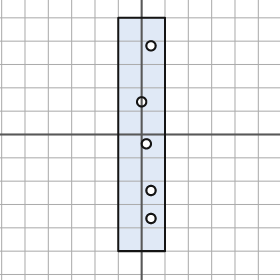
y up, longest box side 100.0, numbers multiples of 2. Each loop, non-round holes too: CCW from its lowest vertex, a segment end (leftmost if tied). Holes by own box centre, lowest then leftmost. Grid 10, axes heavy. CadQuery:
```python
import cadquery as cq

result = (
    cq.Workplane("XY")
    .moveTo(-10.0, -50.0)
    .lineTo(10.0, -50.0)
    .lineTo(10.0, 50.0)
    .lineTo(-10.0, 50.0)
    .close()
    .moveTo(4.0, -36.0)
    .circle(2.0)
    .moveTo(4.0, -24.0)
    .circle(2.0)
    .moveTo(2.0, -4.0)
    .circle(2.0)
    .moveTo(0.0, 14.0)
    .circle(2.0)
    .moveTo(4.0, 38.0)
    .circle(2.0)
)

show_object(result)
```